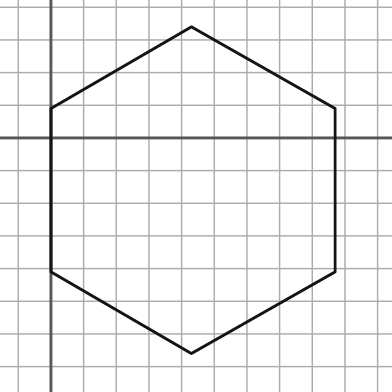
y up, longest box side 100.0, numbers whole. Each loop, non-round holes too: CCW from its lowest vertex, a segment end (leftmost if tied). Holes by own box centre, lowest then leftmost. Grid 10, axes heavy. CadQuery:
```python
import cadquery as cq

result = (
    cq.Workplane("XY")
    .moveTo(43.0, -66.0)
    .lineTo(87.0, -41.0)
    .lineTo(87.0, 9.0)
    .lineTo(43.0, 34.0)
    .lineTo(0.0, 9.0)
    .lineTo(0.0, -41.0)
    .close()
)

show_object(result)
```